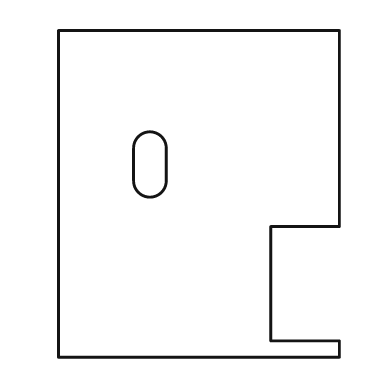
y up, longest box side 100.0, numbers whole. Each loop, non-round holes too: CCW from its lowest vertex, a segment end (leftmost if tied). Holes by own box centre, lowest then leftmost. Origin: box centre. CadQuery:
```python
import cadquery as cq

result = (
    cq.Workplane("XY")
    .moveTo(-43.0, -50.0)
    .lineTo(43.0, -50.0)
    .lineTo(43.0, -45.0)
    .lineTo(22.0, -45.0)
    .lineTo(22.0, -10.0)
    .lineTo(43.0, -10.0)
    .lineTo(43.0, 50.0)
    .lineTo(-43.0, 50.0)
    .close()
    .moveTo(-20.0, 4.0)
    .threePointArc((-15.0, -1.0), (-10.0, 4.0))
    .lineTo(-10.0, 14.0)
    .threePointArc((-15.0, 19.0), (-20.0, 14.0))
    .close()
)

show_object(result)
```